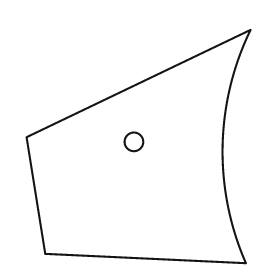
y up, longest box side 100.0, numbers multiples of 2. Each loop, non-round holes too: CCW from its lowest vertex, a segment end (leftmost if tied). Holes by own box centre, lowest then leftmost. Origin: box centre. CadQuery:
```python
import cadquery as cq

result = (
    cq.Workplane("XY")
    .moveTo(46.0, -50.0)
    .threePointArc((36.0, 0.0), (48.0, 50.0))
    .lineTo(-48.0, 4.0)
    .lineTo(-40.0, -46.0)
    .close()
    .moveTo(-2.0, 2.0)
    .circle(4.0)
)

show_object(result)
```